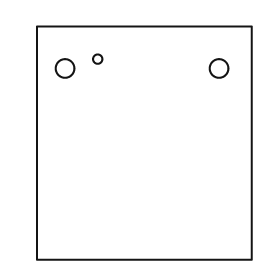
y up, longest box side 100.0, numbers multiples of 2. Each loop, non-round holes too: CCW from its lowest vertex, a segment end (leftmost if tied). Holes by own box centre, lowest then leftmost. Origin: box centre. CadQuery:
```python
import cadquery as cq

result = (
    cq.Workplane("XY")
    .moveTo(-46.0, -50.0)
    .lineTo(46.0, -50.0)
    .lineTo(46.0, 50.0)
    .lineTo(-46.0, 50.0)
    .close()
    .moveTo(-34.0, 32.0)
    .circle(4.0)
    .moveTo(32.0, 32.0)
    .circle(4.0)
    .moveTo(-20.0, 36.0)
    .circle(2.0)
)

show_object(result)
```